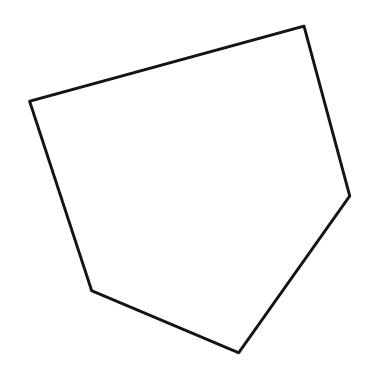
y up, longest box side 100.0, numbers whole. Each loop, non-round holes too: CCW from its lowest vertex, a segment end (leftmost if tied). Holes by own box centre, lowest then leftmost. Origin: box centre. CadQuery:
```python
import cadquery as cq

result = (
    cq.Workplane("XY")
    .moveTo(15.0, -50.0)
    .lineTo(49.0, -2.0)
    .lineTo(35.0, 50.0)
    .lineTo(-49.0, 27.0)
    .lineTo(-30.0, -31.0)
    .close()
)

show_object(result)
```